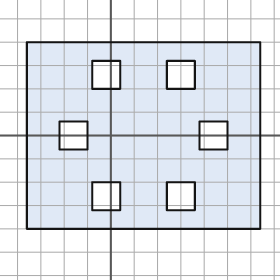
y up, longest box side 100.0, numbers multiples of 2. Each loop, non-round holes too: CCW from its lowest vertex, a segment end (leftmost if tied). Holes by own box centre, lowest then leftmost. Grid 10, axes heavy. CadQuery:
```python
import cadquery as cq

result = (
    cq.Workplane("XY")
    .moveTo(-36.0, -40.0)
    .lineTo(64.0, -40.0)
    .lineTo(64.0, 40.0)
    .lineTo(-36.0, 40.0)
    .close()
    .moveTo(-8.0, -32.0)
    .lineTo(4.0, -32.0)
    .lineTo(4.0, -20.0)
    .lineTo(-8.0, -20.0)
    .close()
    .moveTo(24.0, -32.0)
    .lineTo(36.0, -32.0)
    .lineTo(36.0, -20.0)
    .lineTo(24.0, -20.0)
    .close()
    .moveTo(-22.0, -6.0)
    .lineTo(-10.0, -6.0)
    .lineTo(-10.0, 6.0)
    .lineTo(-22.0, 6.0)
    .close()
    .moveTo(38.0, -6.0)
    .lineTo(50.0, -6.0)
    .lineTo(50.0, 6.0)
    .lineTo(38.0, 6.0)
    .close()
    .moveTo(-8.0, 20.0)
    .lineTo(4.0, 20.0)
    .lineTo(4.0, 32.0)
    .lineTo(-8.0, 32.0)
    .close()
    .moveTo(24.0, 20.0)
    .lineTo(36.0, 20.0)
    .lineTo(36.0, 32.0)
    .lineTo(24.0, 32.0)
    .close()
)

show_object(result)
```